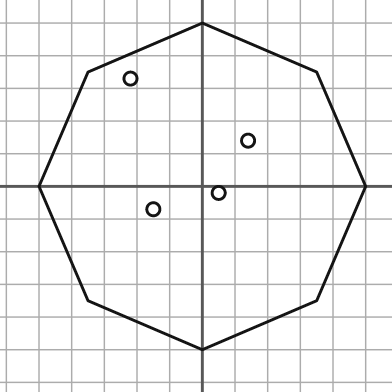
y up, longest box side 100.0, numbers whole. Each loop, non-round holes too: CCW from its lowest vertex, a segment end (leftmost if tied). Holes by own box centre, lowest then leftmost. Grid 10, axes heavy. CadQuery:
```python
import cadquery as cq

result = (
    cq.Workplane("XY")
    .moveTo(0.0, -50.0)
    .lineTo(35.0, -35.0)
    .lineTo(50.0, 0.0)
    .lineTo(35.0, 35.0)
    .lineTo(0.0, 50.0)
    .lineTo(-35.0, 35.0)
    .lineTo(-50.0, 0.0)
    .lineTo(-35.0, -35.0)
    .close()
    .moveTo(-15.0, -7.0)
    .circle(2.0)
    .moveTo(5.0, -2.0)
    .circle(2.0)
    .moveTo(14.0, 14.0)
    .circle(2.0)
    .moveTo(-22.0, 33.0)
    .circle(2.0)
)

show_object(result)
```